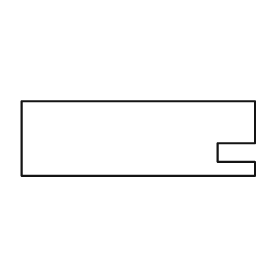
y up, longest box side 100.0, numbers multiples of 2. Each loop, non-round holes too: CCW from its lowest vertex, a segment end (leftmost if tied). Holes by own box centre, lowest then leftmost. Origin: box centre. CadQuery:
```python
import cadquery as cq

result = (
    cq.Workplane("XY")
    .moveTo(-50.0, -16.0)
    .lineTo(50.0, -16.0)
    .lineTo(50.0, -10.0)
    .lineTo(34.0, -10.0)
    .lineTo(34.0, -2.0)
    .lineTo(50.0, -2.0)
    .lineTo(50.0, 16.0)
    .lineTo(-50.0, 16.0)
    .close()
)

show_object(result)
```